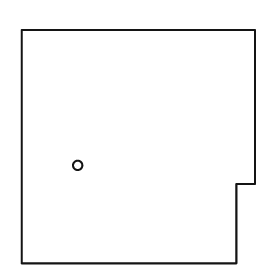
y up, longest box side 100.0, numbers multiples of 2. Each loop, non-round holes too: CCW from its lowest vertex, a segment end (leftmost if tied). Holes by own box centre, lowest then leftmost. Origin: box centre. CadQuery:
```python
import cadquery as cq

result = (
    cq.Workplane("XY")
    .moveTo(-50.0, -50.0)
    .lineTo(42.0, -50.0)
    .lineTo(42.0, -16.0)
    .lineTo(50.0, -16.0)
    .lineTo(50.0, 50.0)
    .lineTo(-50.0, 50.0)
    .close()
    .moveTo(-26.0, -8.0)
    .circle(2.0)
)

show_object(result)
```